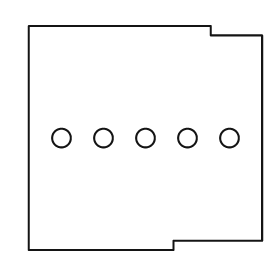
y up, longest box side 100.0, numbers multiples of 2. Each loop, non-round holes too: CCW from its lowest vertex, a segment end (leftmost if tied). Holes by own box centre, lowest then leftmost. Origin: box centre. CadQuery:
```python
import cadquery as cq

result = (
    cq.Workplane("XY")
    .moveTo(-50.0, -48.0)
    .lineTo(12.0, -48.0)
    .lineTo(12.0, -44.0)
    .lineTo(50.0, -44.0)
    .lineTo(50.0, 44.0)
    .lineTo(28.0, 44.0)
    .lineTo(28.0, 48.0)
    .lineTo(-50.0, 48.0)
    .close()
    .moveTo(-36.0, 0.0)
    .circle(4.0)
    .moveTo(-18.0, 0.0)
    .circle(4.0)
    .moveTo(0.0, 0.0)
    .circle(4.0)
    .moveTo(18.0, 0.0)
    .circle(4.0)
    .moveTo(36.0, 0.0)
    .circle(4.0)
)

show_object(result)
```